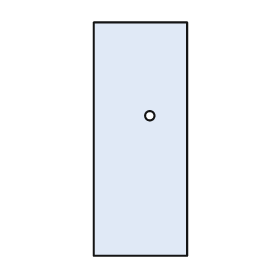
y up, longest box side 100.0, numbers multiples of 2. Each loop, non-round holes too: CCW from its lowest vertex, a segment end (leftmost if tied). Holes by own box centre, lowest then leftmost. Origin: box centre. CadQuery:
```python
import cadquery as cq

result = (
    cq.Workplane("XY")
    .moveTo(-20.0, -50.0)
    .lineTo(20.0, -50.0)
    .lineTo(20.0, 50.0)
    .lineTo(-20.0, 50.0)
    .close()
    .moveTo(4.0, 10.0)
    .circle(2.0)
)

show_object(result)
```